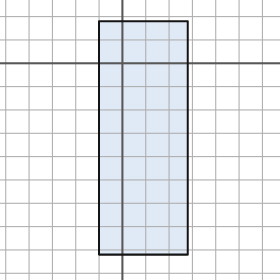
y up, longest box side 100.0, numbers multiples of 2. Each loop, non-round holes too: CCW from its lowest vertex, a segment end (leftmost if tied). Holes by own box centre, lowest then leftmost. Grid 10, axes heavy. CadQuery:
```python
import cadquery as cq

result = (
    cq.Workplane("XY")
    .moveTo(-10.0, -82.0)
    .lineTo(28.0, -82.0)
    .lineTo(28.0, 18.0)
    .lineTo(-10.0, 18.0)
    .close()
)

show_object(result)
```